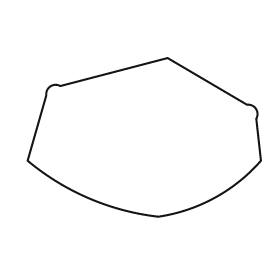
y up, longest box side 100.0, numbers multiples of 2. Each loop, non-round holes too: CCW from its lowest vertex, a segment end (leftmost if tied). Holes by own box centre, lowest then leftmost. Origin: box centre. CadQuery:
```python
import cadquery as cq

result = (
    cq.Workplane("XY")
    .moveTo(6.0, -34.0)
    .threePointArc((30.0, -26.0), (50.0, -10.0))
    .lineTo(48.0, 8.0)
    .threePointArc((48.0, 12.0), (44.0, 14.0))
    .lineTo(10.0, 34.0)
    .lineTo(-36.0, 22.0)
    .threePointArc((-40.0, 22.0), (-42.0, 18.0))
    .lineTo(-50.0, -10.0)
    .threePointArc((-24.0, -26.0), (6.0, -34.0))
    .close()
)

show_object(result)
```